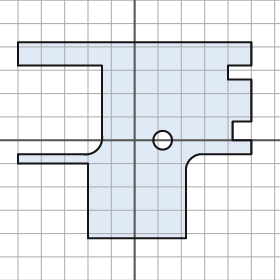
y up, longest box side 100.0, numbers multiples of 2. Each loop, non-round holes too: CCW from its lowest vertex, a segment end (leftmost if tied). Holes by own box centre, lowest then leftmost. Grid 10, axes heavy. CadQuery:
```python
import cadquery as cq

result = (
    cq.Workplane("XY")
    .moveTo(-20.0, -42.0)
    .lineTo(22.0, -42.0)
    .lineTo(22.0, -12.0)
    .threePointArc((24.0, -8.0), (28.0, -6.0))
    .lineTo(50.0, -6.0)
    .lineTo(50.0, 0.0)
    .lineTo(42.0, 0.0)
    .lineTo(42.0, 8.0)
    .lineTo(50.0, 8.0)
    .lineTo(50.0, 26.0)
    .lineTo(40.0, 26.0)
    .lineTo(40.0, 32.0)
    .lineTo(50.0, 32.0)
    .lineTo(50.0, 42.0)
    .lineTo(-50.0, 42.0)
    .lineTo(-50.0, 32.0)
    .lineTo(-14.0, 32.0)
    .lineTo(-14.0, 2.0)
    .threePointArc((-16.0, -4.0), (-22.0, -6.0))
    .lineTo(-50.0, -6.0)
    .lineTo(-50.0, -10.0)
    .lineTo(-20.0, -10.0)
    .close()
    .moveTo(12.0, 0.0)
    .circle(4.0)
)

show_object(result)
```